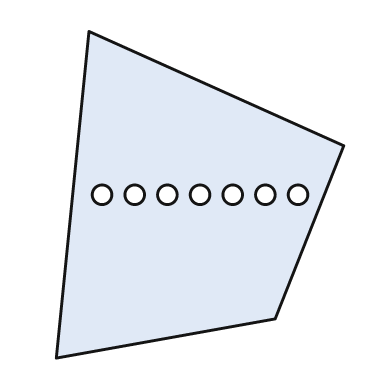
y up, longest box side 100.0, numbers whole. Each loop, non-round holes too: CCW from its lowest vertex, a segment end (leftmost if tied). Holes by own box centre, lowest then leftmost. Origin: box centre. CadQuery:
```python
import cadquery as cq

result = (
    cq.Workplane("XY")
    .moveTo(-44.0, -50.0)
    .lineTo(23.0, -38.0)
    .lineTo(44.0, 15.0)
    .lineTo(-34.0, 50.0)
    .close()
    .moveTo(-30.0, 0.0)
    .circle(3.0)
    .moveTo(-20.0, 0.0)
    .circle(3.0)
    .moveTo(-10.0, 0.0)
    .circle(3.0)
    .moveTo(0.0, 0.0)
    .circle(3.0)
    .moveTo(10.0, 0.0)
    .circle(3.0)
    .moveTo(20.0, 0.0)
    .circle(3.0)
    .moveTo(30.0, 0.0)
    .circle(3.0)
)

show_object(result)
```